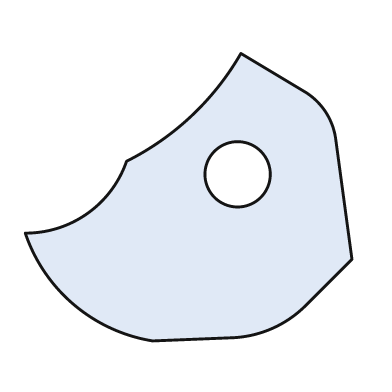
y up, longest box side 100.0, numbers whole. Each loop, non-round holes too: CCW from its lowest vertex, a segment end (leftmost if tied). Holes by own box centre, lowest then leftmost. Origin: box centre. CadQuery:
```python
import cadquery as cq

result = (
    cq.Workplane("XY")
    .moveTo(-11.0, -44.0)
    .lineTo(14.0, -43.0)
    .threePointArc((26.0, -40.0), (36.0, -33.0))
    .lineTo(50.0, -19.0)
    .lineTo(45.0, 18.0)
    .threePointArc((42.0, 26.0), (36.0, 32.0))
    .lineTo(16.0, 44.0)
    .threePointArc((1.0, 25.0), (-19.0, 11.0))
    .threePointArc((-31.0, -5.0), (-50.0, -11.0))
    .threePointArc((-35.0, -33.0), (-11.0, -44.0))
    .close()
    .moveTo(15.0, 7.0)
    .circle(10.0)
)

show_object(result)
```